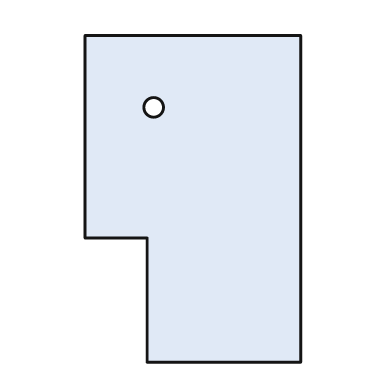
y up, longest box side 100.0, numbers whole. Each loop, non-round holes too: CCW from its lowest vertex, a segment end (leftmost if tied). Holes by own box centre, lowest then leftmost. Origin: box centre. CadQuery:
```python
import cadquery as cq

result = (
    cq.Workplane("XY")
    .moveTo(-14.0, -50.0)
    .lineTo(33.0, -50.0)
    .lineTo(33.0, 50.0)
    .lineTo(-33.0, 50.0)
    .lineTo(-33.0, -12.0)
    .lineTo(-14.0, -12.0)
    .close()
    .moveTo(-12.0, 28.0)
    .circle(3.0)
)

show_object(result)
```